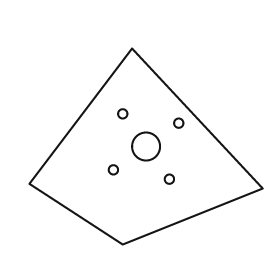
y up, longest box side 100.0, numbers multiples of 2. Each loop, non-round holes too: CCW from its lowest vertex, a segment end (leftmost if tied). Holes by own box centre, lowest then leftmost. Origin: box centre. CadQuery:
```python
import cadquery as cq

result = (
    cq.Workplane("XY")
    .moveTo(-10.0, -42.0)
    .lineTo(50.0, -18.0)
    .lineTo(-6.0, 42.0)
    .lineTo(-50.0, -16.0)
    .close()
    .moveTo(10.0, -14.0)
    .circle(2.0)
    .moveTo(-14.0, -10.0)
    .circle(2.0)
    .moveTo(0.0, 0.0)
    .circle(6.0)
    .moveTo(14.0, 10.0)
    .circle(2.0)
    .moveTo(-10.0, 14.0)
    .circle(2.0)
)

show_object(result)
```